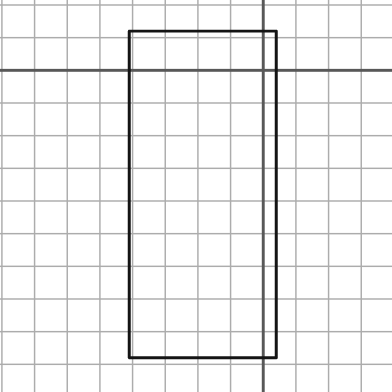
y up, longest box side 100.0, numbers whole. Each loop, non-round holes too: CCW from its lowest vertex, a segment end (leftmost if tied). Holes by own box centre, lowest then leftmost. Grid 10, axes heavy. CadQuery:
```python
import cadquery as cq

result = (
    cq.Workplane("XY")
    .moveTo(-41.0, -88.0)
    .lineTo(4.0, -88.0)
    .lineTo(4.0, 12.0)
    .lineTo(-41.0, 12.0)
    .close()
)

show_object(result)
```